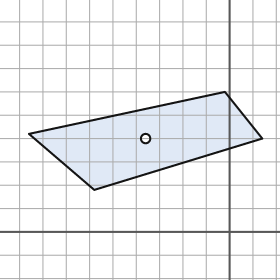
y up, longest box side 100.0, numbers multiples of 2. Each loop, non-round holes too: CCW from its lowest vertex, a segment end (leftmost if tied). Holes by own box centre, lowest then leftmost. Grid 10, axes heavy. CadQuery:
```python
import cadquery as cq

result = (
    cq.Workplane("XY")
    .moveTo(-58.0, 18.0)
    .lineTo(14.0, 40.0)
    .lineTo(-2.0, 60.0)
    .lineTo(-86.0, 42.0)
    .close()
    .moveTo(-36.0, 40.0)
    .circle(2.0)
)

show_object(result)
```